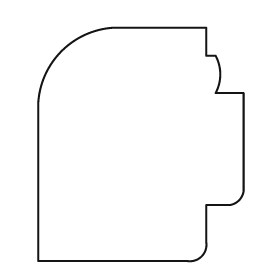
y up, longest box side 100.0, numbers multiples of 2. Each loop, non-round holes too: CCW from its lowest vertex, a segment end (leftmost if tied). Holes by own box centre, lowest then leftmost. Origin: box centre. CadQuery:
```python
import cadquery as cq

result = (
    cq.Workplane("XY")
    .moveTo(-44.0, -50.0)
    .lineTo(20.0, -50.0)
    .threePointArc((26.0, -48.0), (28.0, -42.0))
    .lineTo(28.0, -26.0)
    .lineTo(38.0, -26.0)
    .threePointArc((42.0, -24.0), (44.0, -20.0))
    .lineTo(44.0, 22.0)
    .lineTo(32.0, 22.0)
    .threePointArc((34.0, 30.0), (32.0, 38.0))
    .lineTo(28.0, 38.0)
    .lineTo(28.0, 50.0)
    .lineTo(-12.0, 50.0)
    .threePointArc((-34.0, 40.0), (-44.0, 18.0))
    .close()
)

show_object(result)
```